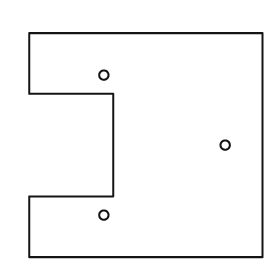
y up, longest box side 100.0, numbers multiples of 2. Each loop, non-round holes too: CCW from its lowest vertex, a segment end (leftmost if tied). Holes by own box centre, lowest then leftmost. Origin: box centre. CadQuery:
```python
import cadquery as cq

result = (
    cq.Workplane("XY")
    .moveTo(-50.0, -48.0)
    .lineTo(50.0, -48.0)
    .lineTo(50.0, 48.0)
    .lineTo(-50.0, 48.0)
    .lineTo(-50.0, 22.0)
    .lineTo(-14.0, 22.0)
    .lineTo(-14.0, -22.0)
    .lineTo(-50.0, -22.0)
    .close()
    .moveTo(-18.0, -30.0)
    .circle(2.0)
    .moveTo(34.0, 0.0)
    .circle(2.0)
    .moveTo(-18.0, 30.0)
    .circle(2.0)
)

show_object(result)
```